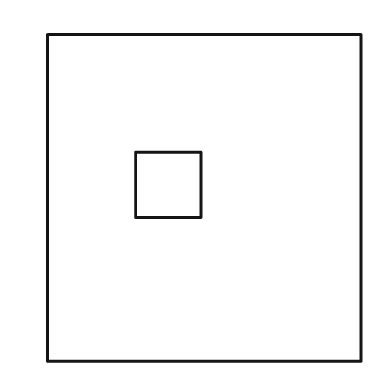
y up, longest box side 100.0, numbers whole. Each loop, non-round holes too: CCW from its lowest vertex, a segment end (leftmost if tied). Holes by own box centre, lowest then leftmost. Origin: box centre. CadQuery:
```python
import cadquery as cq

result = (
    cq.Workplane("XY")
    .moveTo(-48.0, -50.0)
    .lineTo(48.0, -50.0)
    .lineTo(48.0, 50.0)
    .lineTo(-48.0, 50.0)
    .close()
    .moveTo(-21.0, -6.0)
    .lineTo(-1.0, -6.0)
    .lineTo(-1.0, 14.0)
    .lineTo(-21.0, 14.0)
    .close()
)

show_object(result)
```